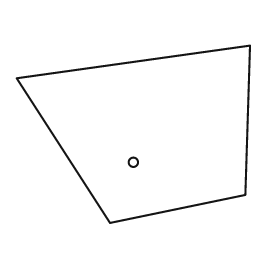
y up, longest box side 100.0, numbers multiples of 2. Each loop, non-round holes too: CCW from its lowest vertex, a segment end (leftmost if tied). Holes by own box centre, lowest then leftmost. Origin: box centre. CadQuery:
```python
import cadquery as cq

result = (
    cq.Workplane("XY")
    .moveTo(-10.0, -38.0)
    .lineTo(48.0, -26.0)
    .lineTo(50.0, 38.0)
    .lineTo(-50.0, 24.0)
    .close()
    .moveTo(0.0, -12.0)
    .circle(2.0)
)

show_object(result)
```